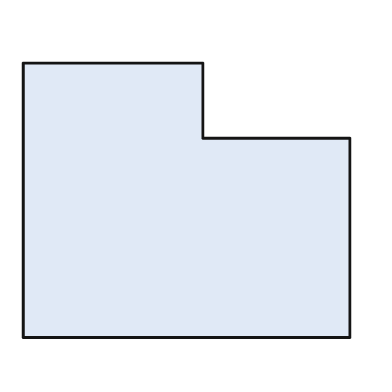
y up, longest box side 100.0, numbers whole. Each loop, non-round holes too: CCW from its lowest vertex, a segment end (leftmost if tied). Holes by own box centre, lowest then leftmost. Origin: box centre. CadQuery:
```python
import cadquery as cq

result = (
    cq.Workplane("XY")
    .moveTo(-50.0, -42.0)
    .lineTo(50.0, -42.0)
    .lineTo(50.0, 19.0)
    .lineTo(5.0, 19.0)
    .lineTo(5.0, 42.0)
    .lineTo(-50.0, 42.0)
    .close()
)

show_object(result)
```